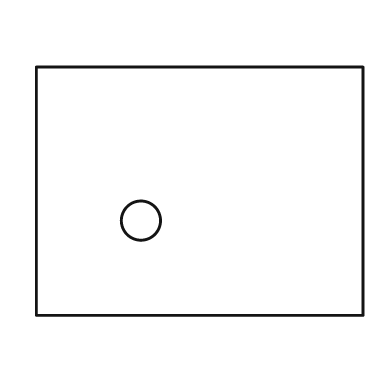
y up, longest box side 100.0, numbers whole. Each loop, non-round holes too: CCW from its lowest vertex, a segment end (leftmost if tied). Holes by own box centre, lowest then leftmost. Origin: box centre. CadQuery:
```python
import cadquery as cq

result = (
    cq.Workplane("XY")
    .moveTo(-50.0, -38.0)
    .lineTo(50.0, -38.0)
    .lineTo(50.0, 38.0)
    .lineTo(-50.0, 38.0)
    .close()
    .moveTo(-18.0, -9.0)
    .circle(6.0)
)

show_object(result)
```